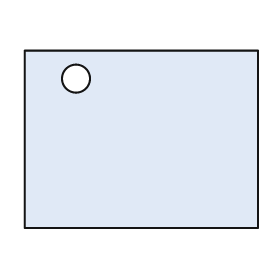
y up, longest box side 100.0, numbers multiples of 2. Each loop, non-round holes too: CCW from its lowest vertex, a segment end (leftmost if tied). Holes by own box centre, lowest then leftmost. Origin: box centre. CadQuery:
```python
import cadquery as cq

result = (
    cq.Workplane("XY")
    .moveTo(-50.0, -38.0)
    .lineTo(50.0, -38.0)
    .lineTo(50.0, 38.0)
    .lineTo(-50.0, 38.0)
    .close()
    .moveTo(-28.0, 26.0)
    .circle(6.0)
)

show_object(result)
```